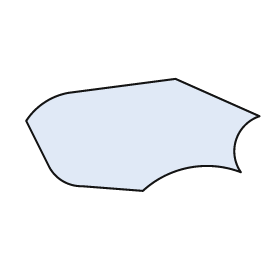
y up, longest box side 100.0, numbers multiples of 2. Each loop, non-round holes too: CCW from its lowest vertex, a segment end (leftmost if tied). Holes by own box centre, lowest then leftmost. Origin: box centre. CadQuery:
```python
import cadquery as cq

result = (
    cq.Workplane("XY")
    .moveTo(0.0, -24.0)
    .threePointArc((20.0, -14.0), (42.0, -16.0))
    .threePointArc((40.0, -2.0), (50.0, 8.0))
    .lineTo(14.0, 24.0)
    .lineTo(-32.0, 18.0)
    .threePointArc((-42.0, 14.0), (-50.0, 6.0))
    .lineTo(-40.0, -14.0)
    .threePointArc((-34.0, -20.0), (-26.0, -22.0))
    .close()
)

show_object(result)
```